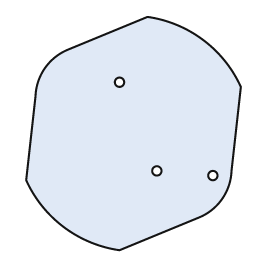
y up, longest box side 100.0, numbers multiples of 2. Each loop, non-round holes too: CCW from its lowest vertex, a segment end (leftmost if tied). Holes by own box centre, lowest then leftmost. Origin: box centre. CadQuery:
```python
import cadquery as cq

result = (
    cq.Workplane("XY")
    .moveTo(-6.0, -50.0)
    .lineTo(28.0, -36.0)
    .threePointArc((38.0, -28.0), (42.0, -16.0))
    .lineTo(46.0, 20.0)
    .threePointArc((30.0, 40.0), (6.0, 50.0))
    .lineTo(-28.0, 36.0)
    .threePointArc((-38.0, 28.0), (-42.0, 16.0))
    .lineTo(-46.0, -20.0)
    .threePointArc((-30.0, -40.0), (-6.0, -50.0))
    .close()
    .moveTo(34.0, -18.0)
    .circle(2.0)
    .moveTo(10.0, -16.0)
    .circle(2.0)
    .moveTo(-6.0, 22.0)
    .circle(2.0)
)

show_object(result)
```